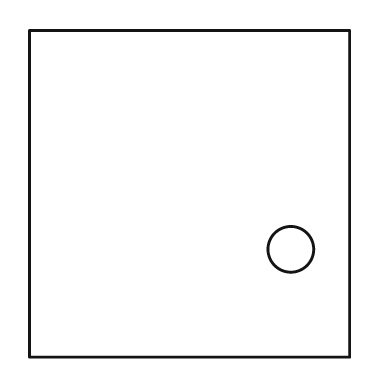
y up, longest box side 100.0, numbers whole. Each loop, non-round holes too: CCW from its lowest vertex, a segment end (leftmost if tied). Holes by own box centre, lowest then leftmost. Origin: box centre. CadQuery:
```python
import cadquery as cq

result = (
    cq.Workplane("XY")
    .moveTo(-49.0, -50.0)
    .lineTo(49.0, -50.0)
    .lineTo(49.0, 50.0)
    .lineTo(-49.0, 50.0)
    .close()
    .moveTo(31.0, -17.0)
    .circle(7.0)
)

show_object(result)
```